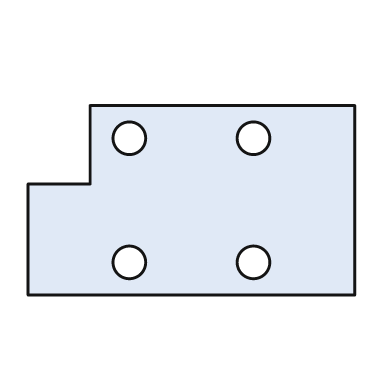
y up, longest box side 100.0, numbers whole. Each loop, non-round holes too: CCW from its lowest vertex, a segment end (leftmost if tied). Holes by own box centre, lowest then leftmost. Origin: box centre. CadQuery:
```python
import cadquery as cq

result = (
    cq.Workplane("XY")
    .moveTo(-50.0, -29.0)
    .lineTo(50.0, -29.0)
    .lineTo(50.0, 29.0)
    .lineTo(-31.0, 29.0)
    .lineTo(-31.0, 5.0)
    .lineTo(-50.0, 5.0)
    .close()
    .moveTo(-19.0, -19.0)
    .circle(5.0)
    .moveTo(19.0, -19.0)
    .circle(5.0)
    .moveTo(-19.0, 19.0)
    .circle(5.0)
    .moveTo(19.0, 19.0)
    .circle(5.0)
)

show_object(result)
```